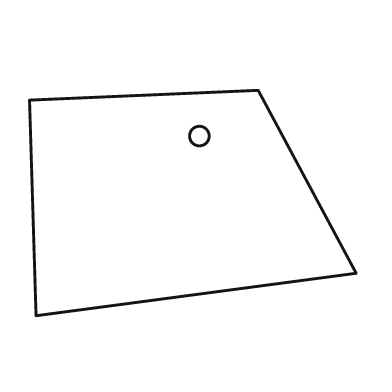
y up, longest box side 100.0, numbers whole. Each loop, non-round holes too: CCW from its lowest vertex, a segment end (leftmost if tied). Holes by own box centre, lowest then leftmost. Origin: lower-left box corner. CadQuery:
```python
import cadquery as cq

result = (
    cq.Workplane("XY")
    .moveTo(2.0, 0.0)
    .lineTo(100.0, 13.0)
    .lineTo(70.0, 69.0)
    .lineTo(0.0, 66.0)
    .close()
    .moveTo(52.0, 55.0)
    .circle(3.0)
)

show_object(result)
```